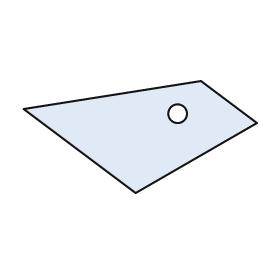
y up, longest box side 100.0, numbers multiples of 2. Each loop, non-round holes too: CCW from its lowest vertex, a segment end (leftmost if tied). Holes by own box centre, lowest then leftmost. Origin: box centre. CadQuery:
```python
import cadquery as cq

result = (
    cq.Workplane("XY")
    .moveTo(-2.0, -24.0)
    .lineTo(50.0, 6.0)
    .lineTo(26.0, 24.0)
    .lineTo(-50.0, 12.0)
    .close()
    .moveTo(16.0, 10.0)
    .circle(4.0)
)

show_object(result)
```